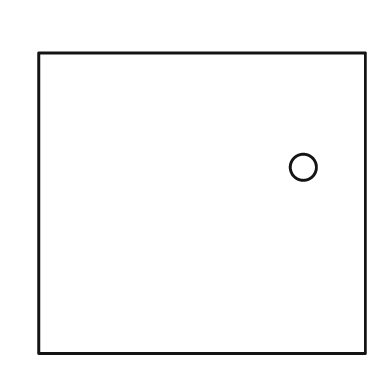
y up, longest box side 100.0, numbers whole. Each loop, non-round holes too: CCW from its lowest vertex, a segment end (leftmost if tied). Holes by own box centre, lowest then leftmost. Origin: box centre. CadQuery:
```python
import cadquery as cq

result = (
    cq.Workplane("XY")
    .moveTo(-50.0, -46.0)
    .lineTo(50.0, -46.0)
    .lineTo(50.0, 46.0)
    .lineTo(-50.0, 46.0)
    .close()
    .moveTo(31.0, 11.0)
    .circle(4.0)
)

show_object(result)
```